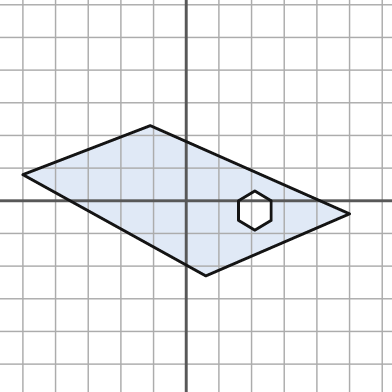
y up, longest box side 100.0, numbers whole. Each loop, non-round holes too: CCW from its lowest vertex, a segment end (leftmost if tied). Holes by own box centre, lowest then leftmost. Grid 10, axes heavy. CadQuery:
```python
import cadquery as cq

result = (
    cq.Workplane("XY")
    .moveTo(6.0, -23.0)
    .lineTo(50.0, -4.0)
    .lineTo(-11.0, 23.0)
    .lineTo(-50.0, 8.0)
    .close()
    .moveTo(21.0, -9.0)
    .lineTo(26.0, -6.0)
    .lineTo(26.0, 0.0)
    .lineTo(21.0, 3.0)
    .lineTo(16.0, 0.0)
    .lineTo(16.0, -6.0)
    .close()
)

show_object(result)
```